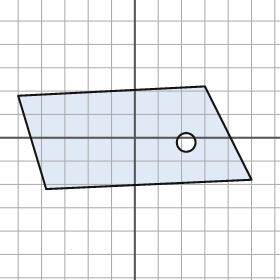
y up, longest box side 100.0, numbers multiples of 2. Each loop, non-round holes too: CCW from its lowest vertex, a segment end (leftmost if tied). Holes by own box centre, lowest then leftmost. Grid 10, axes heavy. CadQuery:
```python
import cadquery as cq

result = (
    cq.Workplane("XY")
    .moveTo(-38.0, -22.0)
    .lineTo(50.0, -18.0)
    .lineTo(30.0, 22.0)
    .lineTo(-50.0, 18.0)
    .close()
    .moveTo(22.0, -2.0)
    .circle(4.0)
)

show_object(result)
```